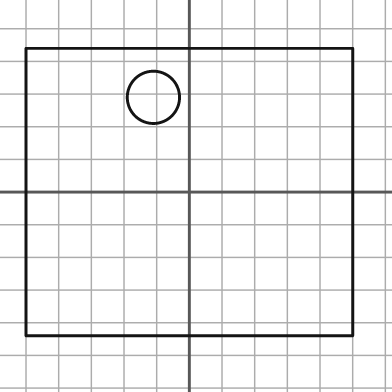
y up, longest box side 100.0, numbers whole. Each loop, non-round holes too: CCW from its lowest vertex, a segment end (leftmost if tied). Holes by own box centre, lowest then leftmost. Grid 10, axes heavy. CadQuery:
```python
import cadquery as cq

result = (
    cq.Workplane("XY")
    .moveTo(-50.0, -44.0)
    .lineTo(50.0, -44.0)
    .lineTo(50.0, 44.0)
    .lineTo(-50.0, 44.0)
    .close()
    .moveTo(-11.0, 29.0)
    .circle(8.0)
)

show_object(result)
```